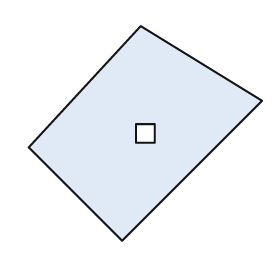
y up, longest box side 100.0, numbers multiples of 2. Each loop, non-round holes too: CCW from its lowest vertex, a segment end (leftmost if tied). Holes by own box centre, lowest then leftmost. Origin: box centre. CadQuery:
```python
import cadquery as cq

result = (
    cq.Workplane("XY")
    .moveTo(-10.0, -46.0)
    .lineTo(50.0, 14.0)
    .lineTo(-2.0, 46.0)
    .lineTo(-50.0, -6.0)
    .close()
    .moveTo(-4.0, -4.0)
    .lineTo(4.0, -4.0)
    .lineTo(4.0, 4.0)
    .lineTo(-4.0, 4.0)
    .close()
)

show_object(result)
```